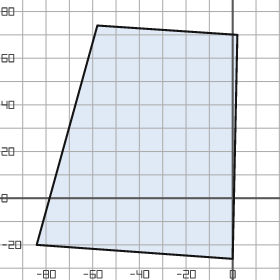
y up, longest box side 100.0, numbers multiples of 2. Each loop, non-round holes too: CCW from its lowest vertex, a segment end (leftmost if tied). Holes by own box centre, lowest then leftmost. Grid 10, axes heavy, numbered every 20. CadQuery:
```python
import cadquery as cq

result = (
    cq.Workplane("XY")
    .moveTo(0.0, -26.0)
    .lineTo(2.0, 70.0)
    .lineTo(-58.0, 74.0)
    .lineTo(-84.0, -20.0)
    .close()
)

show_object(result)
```